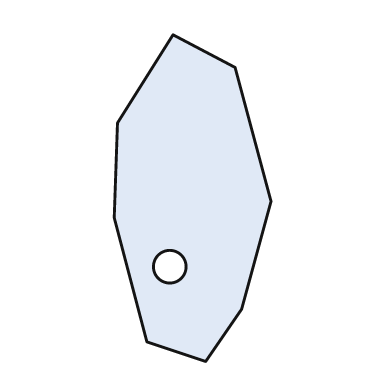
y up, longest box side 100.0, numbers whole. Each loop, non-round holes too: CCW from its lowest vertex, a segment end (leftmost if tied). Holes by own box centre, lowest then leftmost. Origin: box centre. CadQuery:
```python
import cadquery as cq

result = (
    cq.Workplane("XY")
    .moveTo(4.0, -50.0)
    .lineTo(15.0, -34.0)
    .lineTo(24.0, -1.0)
    .lineTo(13.0, 40.0)
    .lineTo(-6.0, 50.0)
    .lineTo(-23.0, 23.0)
    .lineTo(-24.0, -6.0)
    .lineTo(-14.0, -44.0)
    .close()
    .moveTo(-7.0, -21.0)
    .circle(5.0)
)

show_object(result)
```